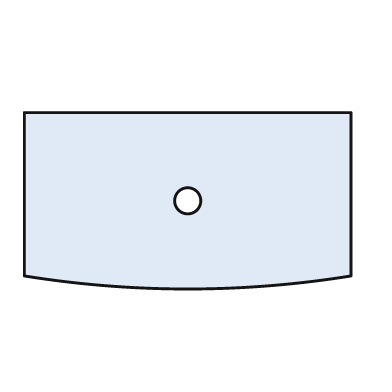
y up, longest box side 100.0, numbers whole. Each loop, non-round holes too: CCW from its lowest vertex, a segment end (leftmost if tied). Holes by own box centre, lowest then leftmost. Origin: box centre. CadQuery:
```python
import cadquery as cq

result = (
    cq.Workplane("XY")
    .moveTo(-50.0, -23.0)
    .threePointArc((0.0, -27.0), (50.0, -23.0))
    .lineTo(50.0, 27.0)
    .lineTo(-50.0, 27.0)
    .close()
    .moveTo(0.0, 0.0)
    .circle(4.0)
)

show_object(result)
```